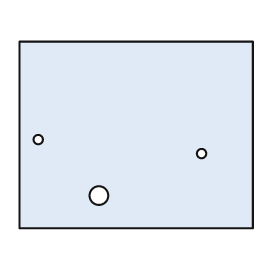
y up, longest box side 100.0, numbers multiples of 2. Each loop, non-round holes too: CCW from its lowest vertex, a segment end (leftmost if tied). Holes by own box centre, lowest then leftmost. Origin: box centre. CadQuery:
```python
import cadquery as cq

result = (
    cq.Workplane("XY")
    .moveTo(-50.0, -40.0)
    .lineTo(50.0, -40.0)
    .lineTo(50.0, 40.0)
    .lineTo(-50.0, 40.0)
    .close()
    .moveTo(-16.0, -26.0)
    .circle(4.0)
    .moveTo(28.0, -8.0)
    .circle(2.0)
    .moveTo(-42.0, -2.0)
    .circle(2.0)
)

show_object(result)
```